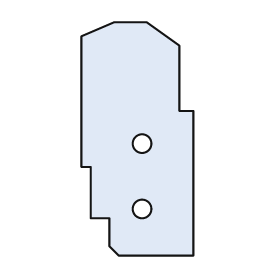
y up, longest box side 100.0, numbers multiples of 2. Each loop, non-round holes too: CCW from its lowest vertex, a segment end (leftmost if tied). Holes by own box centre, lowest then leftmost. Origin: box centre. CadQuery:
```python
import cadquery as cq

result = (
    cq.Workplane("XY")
    .moveTo(-8.0, -50.0)
    .lineTo(24.0, -50.0)
    .lineTo(24.0, 12.0)
    .lineTo(18.0, 12.0)
    .lineTo(18.0, 40.0)
    .lineTo(4.0, 50.0)
    .lineTo(-10.0, 50.0)
    .lineTo(-24.0, 44.0)
    .lineTo(-24.0, -12.0)
    .lineTo(-20.0, -12.0)
    .lineTo(-20.0, -34.0)
    .lineTo(-12.0, -34.0)
    .lineTo(-12.0, -46.0)
    .close()
    .moveTo(2.0, -30.0)
    .circle(4.0)
    .moveTo(2.0, -2.0)
    .circle(4.0)
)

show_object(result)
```